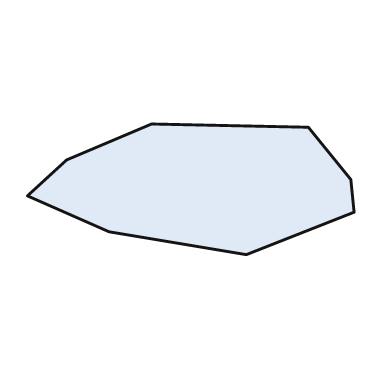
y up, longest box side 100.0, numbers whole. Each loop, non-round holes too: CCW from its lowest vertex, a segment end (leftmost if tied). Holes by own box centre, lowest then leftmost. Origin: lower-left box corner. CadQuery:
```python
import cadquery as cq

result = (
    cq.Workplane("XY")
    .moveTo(67.0, 0.0)
    .lineTo(100.0, 13.0)
    .lineTo(99.0, 23.0)
    .lineTo(86.0, 39.0)
    .lineTo(38.0, 40.0)
    .lineTo(12.0, 29.0)
    .lineTo(0.0, 18.0)
    .lineTo(25.0, 7.0)
    .close()
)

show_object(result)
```